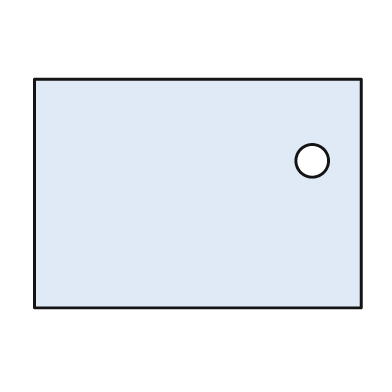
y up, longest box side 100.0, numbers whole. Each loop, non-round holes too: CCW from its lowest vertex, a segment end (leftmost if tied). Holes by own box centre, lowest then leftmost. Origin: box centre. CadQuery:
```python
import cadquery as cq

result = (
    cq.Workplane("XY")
    .moveTo(-50.0, -35.0)
    .lineTo(50.0, -35.0)
    .lineTo(50.0, 35.0)
    .lineTo(-50.0, 35.0)
    .close()
    .moveTo(35.0, 10.0)
    .circle(5.0)
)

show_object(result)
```